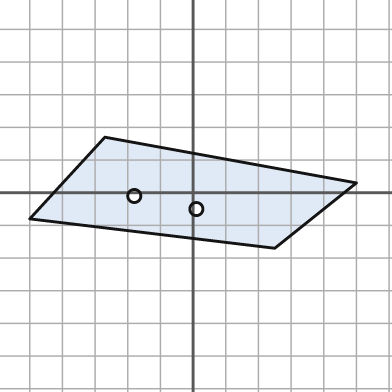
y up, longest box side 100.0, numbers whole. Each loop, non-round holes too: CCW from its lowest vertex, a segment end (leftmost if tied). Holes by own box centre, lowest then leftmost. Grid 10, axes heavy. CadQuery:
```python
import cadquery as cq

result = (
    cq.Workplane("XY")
    .moveTo(25.0, -17.0)
    .lineTo(50.0, 3.0)
    .lineTo(-27.0, 17.0)
    .lineTo(-50.0, -8.0)
    .close()
    .moveTo(1.0, -5.0)
    .circle(2.0)
    .moveTo(-18.0, -1.0)
    .circle(2.0)
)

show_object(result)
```